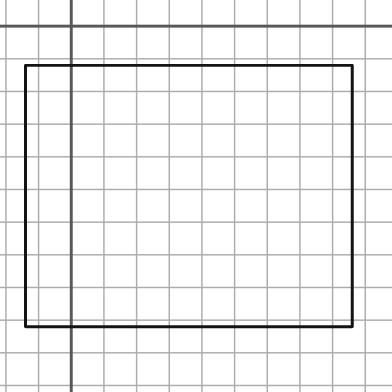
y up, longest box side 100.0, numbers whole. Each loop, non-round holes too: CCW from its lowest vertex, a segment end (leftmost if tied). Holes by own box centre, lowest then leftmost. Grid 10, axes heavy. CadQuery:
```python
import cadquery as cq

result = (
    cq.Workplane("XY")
    .moveTo(-14.0, -92.0)
    .lineTo(86.0, -92.0)
    .lineTo(86.0, -12.0)
    .lineTo(-14.0, -12.0)
    .close()
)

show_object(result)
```